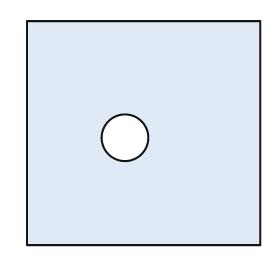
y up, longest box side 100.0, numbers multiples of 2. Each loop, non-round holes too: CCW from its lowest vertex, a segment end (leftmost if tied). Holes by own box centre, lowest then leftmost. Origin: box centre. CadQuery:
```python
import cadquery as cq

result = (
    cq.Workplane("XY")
    .moveTo(-50.0, -48.0)
    .lineTo(50.0, -48.0)
    .lineTo(50.0, 48.0)
    .lineTo(-50.0, 48.0)
    .close()
    .moveTo(-8.0, -2.0)
    .circle(10.0)
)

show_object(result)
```